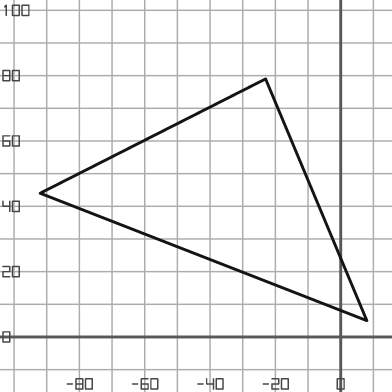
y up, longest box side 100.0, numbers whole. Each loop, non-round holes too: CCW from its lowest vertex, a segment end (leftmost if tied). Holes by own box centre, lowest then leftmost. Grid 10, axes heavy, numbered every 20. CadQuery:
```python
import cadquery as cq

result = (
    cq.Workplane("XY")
    .moveTo(8.0, 5.0)
    .lineTo(-23.0, 79.0)
    .lineTo(-92.0, 44.0)
    .close()
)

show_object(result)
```